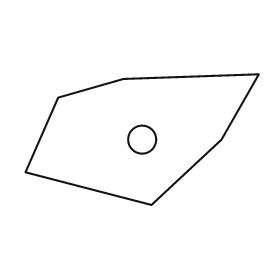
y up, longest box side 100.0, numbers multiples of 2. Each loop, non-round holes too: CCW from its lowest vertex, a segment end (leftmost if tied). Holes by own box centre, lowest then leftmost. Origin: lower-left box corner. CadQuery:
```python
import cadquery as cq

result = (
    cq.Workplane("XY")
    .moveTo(54.0, 0.0)
    .lineTo(84.0, 28.0)
    .lineTo(100.0, 56.0)
    .lineTo(42.0, 54.0)
    .lineTo(14.0, 46.0)
    .lineTo(0.0, 14.0)
    .close()
    .moveTo(50.0, 28.0)
    .circle(6.0)
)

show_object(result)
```